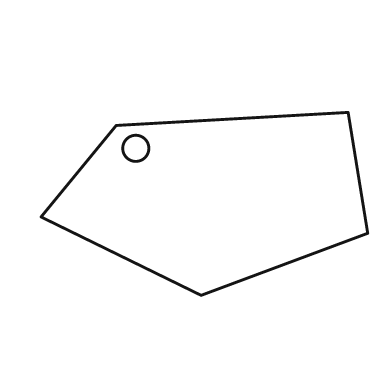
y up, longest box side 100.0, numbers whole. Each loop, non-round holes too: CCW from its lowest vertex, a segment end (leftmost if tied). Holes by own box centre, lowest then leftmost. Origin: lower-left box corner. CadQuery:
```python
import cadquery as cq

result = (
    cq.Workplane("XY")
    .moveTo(49.0, 0.0)
    .lineTo(100.0, 19.0)
    .lineTo(94.0, 56.0)
    .lineTo(23.0, 52.0)
    .lineTo(0.0, 24.0)
    .close()
    .moveTo(29.0, 45.0)
    .circle(4.0)
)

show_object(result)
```